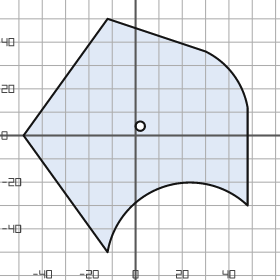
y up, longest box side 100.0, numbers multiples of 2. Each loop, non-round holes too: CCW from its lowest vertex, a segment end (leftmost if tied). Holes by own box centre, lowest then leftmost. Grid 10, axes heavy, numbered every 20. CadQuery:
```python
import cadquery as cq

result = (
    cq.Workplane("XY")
    .moveTo(-12.0, -50.0)
    .threePointArc((12.0, -22.0), (48.0, -30.0))
    .lineTo(48.0, 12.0)
    .threePointArc((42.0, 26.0), (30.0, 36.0))
    .lineTo(-12.0, 50.0)
    .lineTo(-48.0, 0.0)
    .close()
    .moveTo(2.0, 4.0)
    .circle(2.0)
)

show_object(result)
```